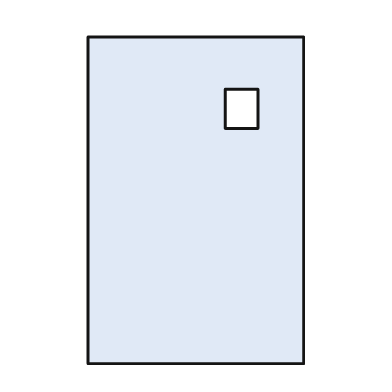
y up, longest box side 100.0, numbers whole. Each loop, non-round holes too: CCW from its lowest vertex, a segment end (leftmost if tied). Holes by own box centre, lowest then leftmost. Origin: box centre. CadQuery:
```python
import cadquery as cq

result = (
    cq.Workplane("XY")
    .moveTo(-33.0, -50.0)
    .lineTo(33.0, -50.0)
    .lineTo(33.0, 50.0)
    .lineTo(-33.0, 50.0)
    .close()
    .moveTo(9.0, 22.0)
    .lineTo(19.0, 22.0)
    .lineTo(19.0, 34.0)
    .lineTo(9.0, 34.0)
    .close()
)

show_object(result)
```